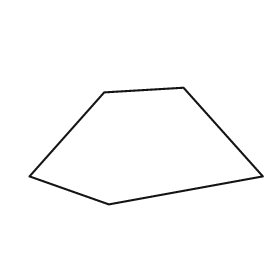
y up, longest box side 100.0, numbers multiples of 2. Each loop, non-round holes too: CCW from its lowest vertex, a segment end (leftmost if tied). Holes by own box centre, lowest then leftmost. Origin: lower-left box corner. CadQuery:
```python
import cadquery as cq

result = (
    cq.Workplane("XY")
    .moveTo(34.0, 0.0)
    .lineTo(100.0, 12.0)
    .lineTo(66.0, 50.0)
    .lineTo(32.0, 48.0)
    .lineTo(0.0, 12.0)
    .close()
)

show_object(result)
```